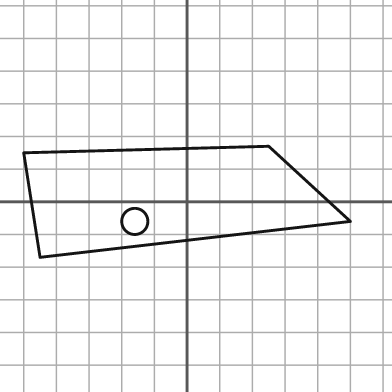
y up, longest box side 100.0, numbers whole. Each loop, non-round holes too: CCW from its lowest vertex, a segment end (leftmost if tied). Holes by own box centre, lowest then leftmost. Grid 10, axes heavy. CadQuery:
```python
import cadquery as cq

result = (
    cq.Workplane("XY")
    .moveTo(-45.0, -17.0)
    .lineTo(50.0, -6.0)
    .lineTo(25.0, 17.0)
    .lineTo(-50.0, 15.0)
    .close()
    .moveTo(-16.0, -6.0)
    .circle(4.0)
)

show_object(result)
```